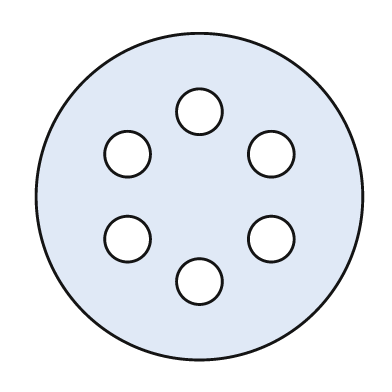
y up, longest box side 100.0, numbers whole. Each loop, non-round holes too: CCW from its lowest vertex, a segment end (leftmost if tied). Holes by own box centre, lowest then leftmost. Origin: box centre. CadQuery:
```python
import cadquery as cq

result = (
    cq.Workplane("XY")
    .moveTo(0.0, 0.0)
    .circle(50.0)
    .moveTo(0.0, -26.0)
    .circle(7.0)
    .moveTo(-22.0, -13.0)
    .circle(7.0)
    .moveTo(22.0, -13.0)
    .circle(7.0)
    .moveTo(-22.0, 13.0)
    .circle(7.0)
    .moveTo(22.0, 13.0)
    .circle(7.0)
    .moveTo(0.0, 26.0)
    .circle(7.0)
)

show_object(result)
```